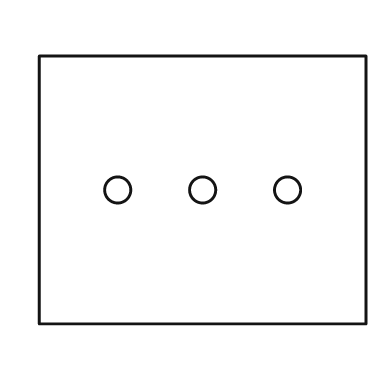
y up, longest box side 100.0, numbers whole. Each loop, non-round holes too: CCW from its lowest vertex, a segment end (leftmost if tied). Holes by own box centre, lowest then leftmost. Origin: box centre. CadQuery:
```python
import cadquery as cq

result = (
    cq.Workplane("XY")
    .moveTo(-50.0, -41.0)
    .lineTo(50.0, -41.0)
    .lineTo(50.0, 41.0)
    .lineTo(-50.0, 41.0)
    .close()
    .moveTo(-26.0, 0.0)
    .circle(4.0)
    .moveTo(0.0, 0.0)
    .circle(4.0)
    .moveTo(26.0, 0.0)
    .circle(4.0)
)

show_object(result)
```